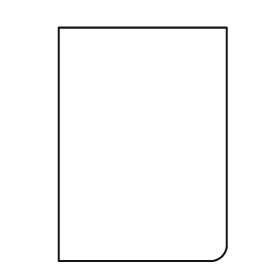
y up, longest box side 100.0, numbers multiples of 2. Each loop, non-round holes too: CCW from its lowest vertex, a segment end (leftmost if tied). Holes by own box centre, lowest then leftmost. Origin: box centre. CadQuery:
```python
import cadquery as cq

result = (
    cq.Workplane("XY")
    .moveTo(-36.0, -50.0)
    .lineTo(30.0, -50.0)
    .threePointArc((34.0, -48.0), (36.0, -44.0))
    .lineTo(36.0, 50.0)
    .lineTo(-36.0, 50.0)
    .close()
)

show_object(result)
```